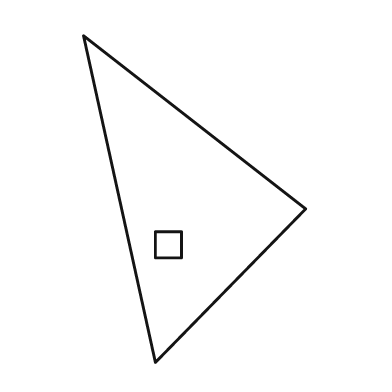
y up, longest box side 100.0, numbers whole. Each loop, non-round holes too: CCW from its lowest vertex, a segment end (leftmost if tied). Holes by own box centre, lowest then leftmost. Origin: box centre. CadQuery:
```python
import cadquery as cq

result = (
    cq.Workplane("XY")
    .moveTo(-12.0, -50.0)
    .lineTo(34.0, -3.0)
    .lineTo(-34.0, 50.0)
    .close()
    .moveTo(-12.0, -18.0)
    .lineTo(-4.0, -18.0)
    .lineTo(-4.0, -10.0)
    .lineTo(-12.0, -10.0)
    .close()
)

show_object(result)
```